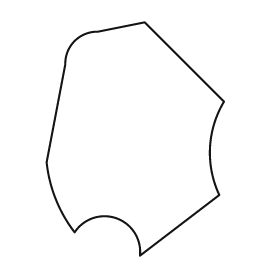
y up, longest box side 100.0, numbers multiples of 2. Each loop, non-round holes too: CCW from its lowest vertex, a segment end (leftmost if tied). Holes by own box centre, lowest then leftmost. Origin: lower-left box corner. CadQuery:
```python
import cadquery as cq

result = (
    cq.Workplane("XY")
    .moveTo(40.0, 0.0)
    .lineTo(74.0, 26.0)
    .threePointArc((70.0, 46.0), (76.0, 66.0))
    .lineTo(42.0, 100.0)
    .lineTo(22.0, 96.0)
    .threePointArc((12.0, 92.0), (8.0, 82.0))
    .lineTo(0.0, 40.0)
    .threePointArc((4.0, 24.0), (12.0, 10.0))
    .threePointArc((30.0, 16.0), (40.0, 0.0))
    .close()
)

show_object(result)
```